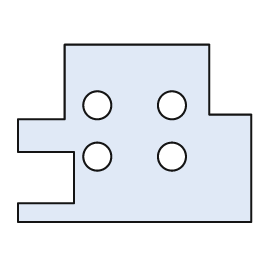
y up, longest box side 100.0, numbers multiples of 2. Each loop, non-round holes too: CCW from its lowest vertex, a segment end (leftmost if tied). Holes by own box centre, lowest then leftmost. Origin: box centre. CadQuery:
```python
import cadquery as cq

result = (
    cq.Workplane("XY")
    .moveTo(-50.0, -38.0)
    .lineTo(50.0, -38.0)
    .lineTo(50.0, 8.0)
    .lineTo(32.0, 8.0)
    .lineTo(32.0, 38.0)
    .lineTo(-30.0, 38.0)
    .lineTo(-30.0, 6.0)
    .lineTo(-50.0, 6.0)
    .lineTo(-50.0, -8.0)
    .lineTo(-26.0, -8.0)
    .lineTo(-26.0, -30.0)
    .lineTo(-50.0, -30.0)
    .close()
    .moveTo(-16.0, -10.0)
    .circle(6.0)
    .moveTo(16.0, -10.0)
    .circle(6.0)
    .moveTo(-16.0, 12.0)
    .circle(6.0)
    .moveTo(16.0, 12.0)
    .circle(6.0)
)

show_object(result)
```